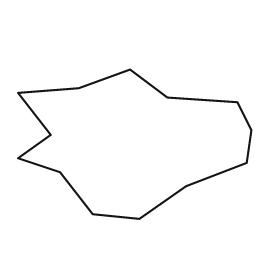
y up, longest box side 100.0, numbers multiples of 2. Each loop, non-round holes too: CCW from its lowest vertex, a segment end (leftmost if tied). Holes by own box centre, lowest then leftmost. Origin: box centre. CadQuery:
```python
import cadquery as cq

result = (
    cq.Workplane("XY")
    .moveTo(2.0, -32.0)
    .lineTo(22.0, -18.0)
    .lineTo(48.0, -8.0)
    .lineTo(50.0, 6.0)
    .lineTo(44.0, 18.0)
    .lineTo(14.0, 20.0)
    .lineTo(-2.0, 32.0)
    .lineTo(-24.0, 24.0)
    .lineTo(-50.0, 22.0)
    .lineTo(-36.0, 4.0)
    .lineTo(-50.0, -6.0)
    .lineTo(-32.0, -12.0)
    .lineTo(-18.0, -30.0)
    .close()
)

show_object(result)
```